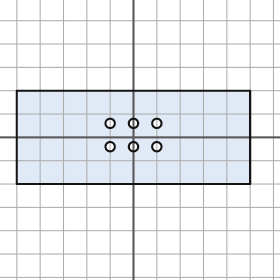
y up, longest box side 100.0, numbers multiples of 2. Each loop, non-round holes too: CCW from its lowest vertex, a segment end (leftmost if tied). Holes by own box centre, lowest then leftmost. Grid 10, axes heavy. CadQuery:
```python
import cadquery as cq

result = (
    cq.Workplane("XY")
    .moveTo(-50.0, -20.0)
    .lineTo(50.0, -20.0)
    .lineTo(50.0, 20.0)
    .lineTo(-50.0, 20.0)
    .close()
    .moveTo(-10.0, -4.0)
    .circle(2.0)
    .moveTo(0.0, -4.0)
    .circle(2.0)
    .moveTo(10.0, -4.0)
    .circle(2.0)
    .moveTo(-10.0, 6.0)
    .circle(2.0)
    .moveTo(0.0, 6.0)
    .circle(2.0)
    .moveTo(10.0, 6.0)
    .circle(2.0)
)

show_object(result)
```